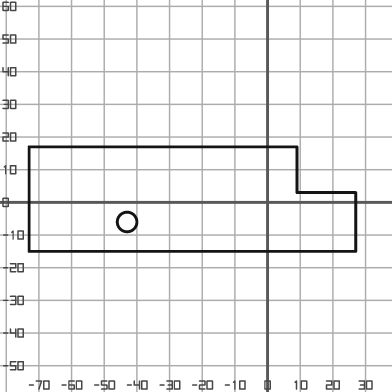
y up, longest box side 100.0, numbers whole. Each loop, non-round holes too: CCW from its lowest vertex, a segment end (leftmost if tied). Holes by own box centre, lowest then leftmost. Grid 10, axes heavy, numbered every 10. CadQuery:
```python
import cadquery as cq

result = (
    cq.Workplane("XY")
    .moveTo(-73.0, -15.0)
    .lineTo(27.0, -15.0)
    .lineTo(27.0, 3.0)
    .lineTo(9.0, 3.0)
    .lineTo(9.0, 17.0)
    .lineTo(-73.0, 17.0)
    .close()
    .moveTo(-43.0, -6.0)
    .circle(3.0)
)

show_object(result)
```